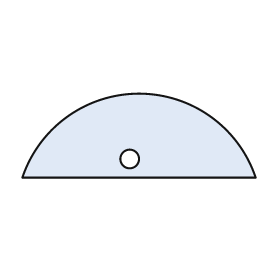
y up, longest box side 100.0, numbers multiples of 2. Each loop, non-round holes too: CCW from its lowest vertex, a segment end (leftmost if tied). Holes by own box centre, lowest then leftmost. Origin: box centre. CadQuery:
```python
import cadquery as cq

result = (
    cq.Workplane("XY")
    .moveTo(-50.0, -18.0)
    .lineTo(50.0, -18.0)
    .threePointArc((0.0, 18.0), (-50.0, -18.0))
    .close()
    .moveTo(-4.0, -10.0)
    .circle(4.0)
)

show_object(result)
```